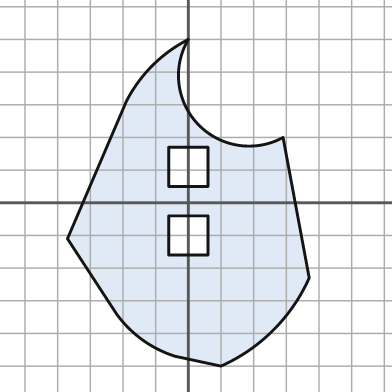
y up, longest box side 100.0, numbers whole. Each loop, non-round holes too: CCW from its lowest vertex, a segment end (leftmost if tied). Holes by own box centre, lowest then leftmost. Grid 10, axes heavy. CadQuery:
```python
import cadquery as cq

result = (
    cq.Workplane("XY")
    .moveTo(10.0, -50.0)
    .threePointArc((26.0, -39.0), (37.0, -23.0))
    .lineTo(29.0, 20.0)
    .threePointArc((3.0, 24.0), (0.0, 50.0))
    .threePointArc((-11.0, 42.0), (-19.0, 31.0))
    .lineTo(-37.0, -11.0)
    .lineTo(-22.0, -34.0)
    .threePointArc((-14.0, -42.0), (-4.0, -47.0))
    .close()
    .moveTo(-6.0, -16.0)
    .lineTo(6.0, -16.0)
    .lineTo(6.0, -4.0)
    .lineTo(-6.0, -4.0)
    .close()
    .moveTo(-6.0, 5.0)
    .lineTo(6.0, 5.0)
    .lineTo(6.0, 17.0)
    .lineTo(-6.0, 17.0)
    .close()
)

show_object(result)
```